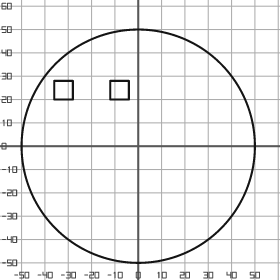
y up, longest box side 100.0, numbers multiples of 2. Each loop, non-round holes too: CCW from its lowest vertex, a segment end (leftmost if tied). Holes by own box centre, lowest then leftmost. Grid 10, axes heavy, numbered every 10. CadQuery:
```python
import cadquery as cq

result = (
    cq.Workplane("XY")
    .moveTo(0.0, 0.0)
    .circle(50.0)
    .moveTo(-36.0, 20.0)
    .lineTo(-28.0, 20.0)
    .lineTo(-28.0, 28.0)
    .lineTo(-36.0, 28.0)
    .close()
    .moveTo(-12.0, 20.0)
    .lineTo(-4.0, 20.0)
    .lineTo(-4.0, 28.0)
    .lineTo(-12.0, 28.0)
    .close()
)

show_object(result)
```